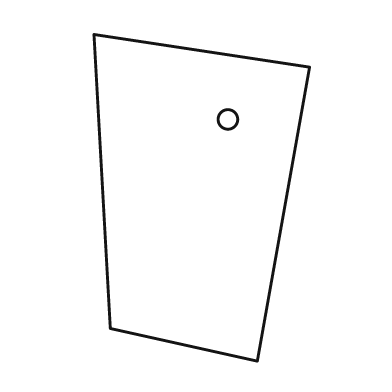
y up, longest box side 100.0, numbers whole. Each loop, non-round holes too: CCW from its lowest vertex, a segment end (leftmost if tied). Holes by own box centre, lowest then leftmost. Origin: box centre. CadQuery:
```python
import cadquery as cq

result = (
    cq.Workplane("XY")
    .moveTo(17.0, -50.0)
    .lineTo(33.0, 40.0)
    .lineTo(-33.0, 50.0)
    .lineTo(-28.0, -40.0)
    .close()
    .moveTo(8.0, 24.0)
    .circle(3.0)
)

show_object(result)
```